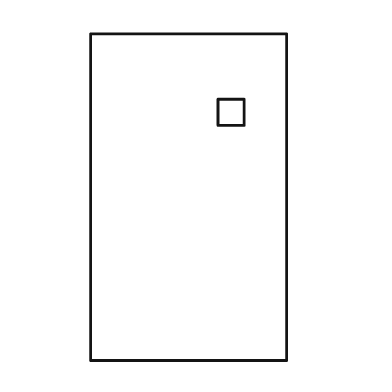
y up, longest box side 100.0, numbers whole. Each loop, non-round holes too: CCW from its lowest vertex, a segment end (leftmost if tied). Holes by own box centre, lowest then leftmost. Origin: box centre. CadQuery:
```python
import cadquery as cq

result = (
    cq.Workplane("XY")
    .moveTo(-30.0, -50.0)
    .lineTo(30.0, -50.0)
    .lineTo(30.0, 50.0)
    .lineTo(-30.0, 50.0)
    .close()
    .moveTo(9.0, 22.0)
    .lineTo(17.0, 22.0)
    .lineTo(17.0, 30.0)
    .lineTo(9.0, 30.0)
    .close()
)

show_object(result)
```